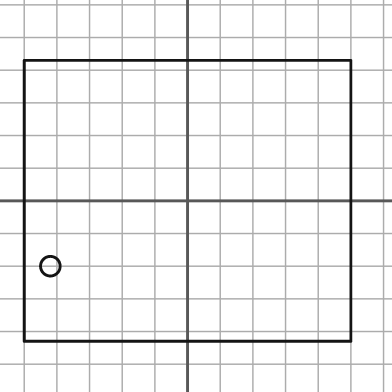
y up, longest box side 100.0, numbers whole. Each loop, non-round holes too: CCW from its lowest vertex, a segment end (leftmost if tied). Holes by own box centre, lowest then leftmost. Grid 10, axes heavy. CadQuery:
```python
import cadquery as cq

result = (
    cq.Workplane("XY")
    .moveTo(-50.0, -43.0)
    .lineTo(50.0, -43.0)
    .lineTo(50.0, 43.0)
    .lineTo(-50.0, 43.0)
    .close()
    .moveTo(-42.0, -20.0)
    .circle(3.0)
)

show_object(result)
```